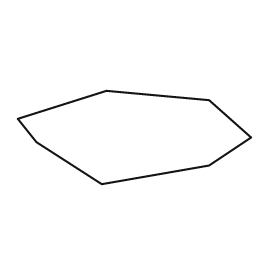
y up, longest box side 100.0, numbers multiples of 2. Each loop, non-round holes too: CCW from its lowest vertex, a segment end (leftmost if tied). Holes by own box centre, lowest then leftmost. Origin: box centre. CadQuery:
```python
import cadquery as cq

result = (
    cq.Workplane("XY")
    .moveTo(-14.0, -20.0)
    .lineTo(32.0, -12.0)
    .lineTo(50.0, 0.0)
    .lineTo(32.0, 16.0)
    .lineTo(-12.0, 20.0)
    .lineTo(-50.0, 8.0)
    .lineTo(-42.0, -2.0)
    .close()
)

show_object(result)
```